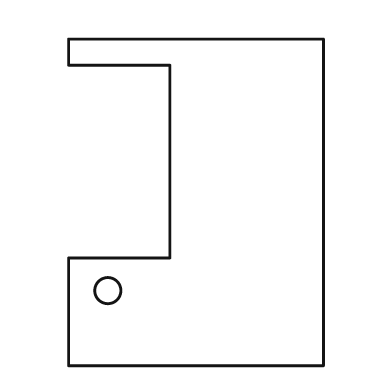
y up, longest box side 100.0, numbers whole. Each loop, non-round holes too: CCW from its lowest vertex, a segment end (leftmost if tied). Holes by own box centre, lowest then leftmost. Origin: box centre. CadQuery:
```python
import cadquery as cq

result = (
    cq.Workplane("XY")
    .moveTo(-39.0, -50.0)
    .lineTo(39.0, -50.0)
    .lineTo(39.0, 50.0)
    .lineTo(-39.0, 50.0)
    .lineTo(-39.0, 42.0)
    .lineTo(-8.0, 42.0)
    .lineTo(-8.0, -17.0)
    .lineTo(-39.0, -17.0)
    .close()
    .moveTo(-27.0, -27.0)
    .circle(4.0)
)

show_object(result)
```